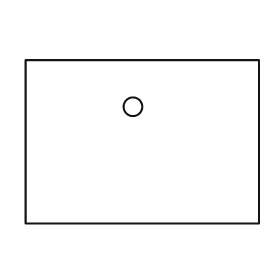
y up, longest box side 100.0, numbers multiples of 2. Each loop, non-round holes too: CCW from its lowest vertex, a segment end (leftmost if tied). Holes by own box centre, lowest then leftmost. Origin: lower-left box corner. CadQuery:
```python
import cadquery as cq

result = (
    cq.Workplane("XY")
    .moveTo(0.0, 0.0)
    .lineTo(100.0, 0.0)
    .lineTo(100.0, 70.0)
    .lineTo(0.0, 70.0)
    .close()
    .moveTo(46.0, 50.0)
    .circle(4.0)
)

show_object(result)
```